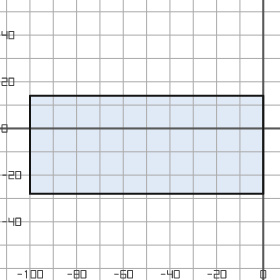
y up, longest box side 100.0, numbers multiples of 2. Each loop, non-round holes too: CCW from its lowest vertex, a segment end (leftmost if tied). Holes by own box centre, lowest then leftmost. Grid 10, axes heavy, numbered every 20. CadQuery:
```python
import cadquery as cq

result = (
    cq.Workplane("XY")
    .moveTo(-100.0, -28.0)
    .lineTo(0.0, -28.0)
    .lineTo(0.0, 14.0)
    .lineTo(-100.0, 14.0)
    .close()
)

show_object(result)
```